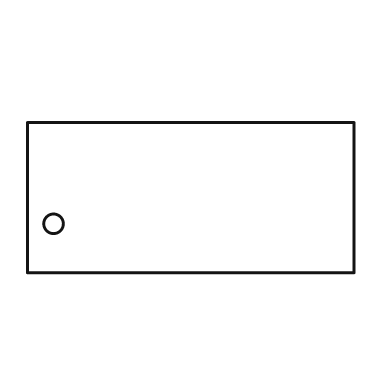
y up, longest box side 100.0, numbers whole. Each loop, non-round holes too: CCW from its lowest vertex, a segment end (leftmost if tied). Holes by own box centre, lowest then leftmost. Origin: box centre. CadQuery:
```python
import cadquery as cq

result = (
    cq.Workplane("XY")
    .moveTo(-50.0, -23.0)
    .lineTo(50.0, -23.0)
    .lineTo(50.0, 23.0)
    .lineTo(-50.0, 23.0)
    .close()
    .moveTo(-42.0, -8.0)
    .circle(3.0)
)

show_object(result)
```